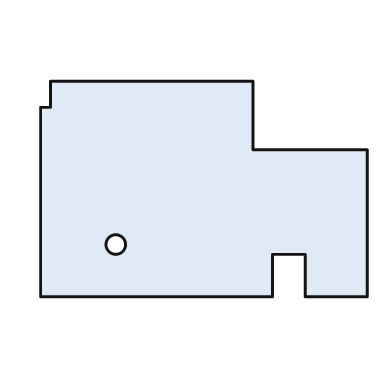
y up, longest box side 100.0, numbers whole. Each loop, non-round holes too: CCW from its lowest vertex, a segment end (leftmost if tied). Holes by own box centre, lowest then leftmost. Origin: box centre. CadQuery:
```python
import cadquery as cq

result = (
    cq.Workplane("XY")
    .moveTo(-50.0, -33.0)
    .lineTo(21.0, -33.0)
    .lineTo(21.0, -20.0)
    .lineTo(31.0, -20.0)
    .lineTo(31.0, -33.0)
    .lineTo(50.0, -33.0)
    .lineTo(50.0, 12.0)
    .lineTo(15.0, 12.0)
    .lineTo(15.0, 33.0)
    .lineTo(-47.0, 33.0)
    .lineTo(-47.0, 25.0)
    .lineTo(-50.0, 25.0)
    .close()
    .moveTo(-27.0, -17.0)
    .circle(3.0)
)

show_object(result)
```